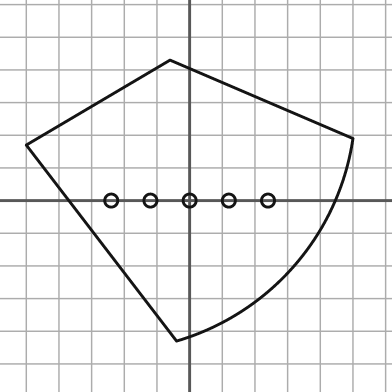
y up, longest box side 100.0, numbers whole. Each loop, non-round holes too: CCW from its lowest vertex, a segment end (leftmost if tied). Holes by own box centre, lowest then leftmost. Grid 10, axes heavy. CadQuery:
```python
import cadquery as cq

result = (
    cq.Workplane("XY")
    .moveTo(-4.0, -43.0)
    .threePointArc((32.0, -20.0), (50.0, 19.0))
    .lineTo(-6.0, 43.0)
    .lineTo(-50.0, 17.0)
    .close()
    .moveTo(-24.0, 0.0)
    .circle(2.0)
    .moveTo(-12.0, 0.0)
    .circle(2.0)
    .moveTo(0.0, 0.0)
    .circle(2.0)
    .moveTo(12.0, 0.0)
    .circle(2.0)
    .moveTo(24.0, 0.0)
    .circle(2.0)
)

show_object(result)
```